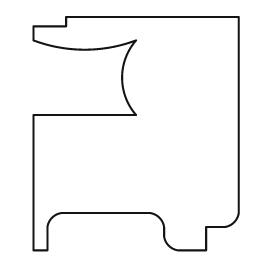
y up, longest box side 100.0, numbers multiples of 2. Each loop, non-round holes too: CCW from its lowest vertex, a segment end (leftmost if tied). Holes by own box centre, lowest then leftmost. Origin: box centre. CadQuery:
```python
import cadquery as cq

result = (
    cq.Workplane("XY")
    .moveTo(-44.0, -50.0)
    .lineTo(-38.0, -50.0)
    .lineTo(-38.0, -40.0)
    .threePointArc((-36.0, -36.0), (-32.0, -34.0))
    .lineTo(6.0, -34.0)
    .threePointArc((10.0, -36.0), (12.0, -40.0))
    .lineTo(12.0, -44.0)
    .threePointArc((14.0, -48.0), (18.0, -50.0))
    .lineTo(30.0, -50.0)
    .lineTo(30.0, -40.0)
    .lineTo(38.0, -40.0)
    .threePointArc((42.0, -38.0), (44.0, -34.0))
    .lineTo(44.0, 50.0)
    .lineTo(-30.0, 50.0)
    .lineTo(-30.0, 46.0)
    .lineTo(-44.0, 46.0)
    .lineTo(-44.0, 40.0)
    .threePointArc((-22.0, 36.0), (0.0, 40.0))
    .threePointArc((-6.0, 24.0), (0.0, 8.0))
    .lineTo(-44.0, 8.0)
    .close()
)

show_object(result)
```